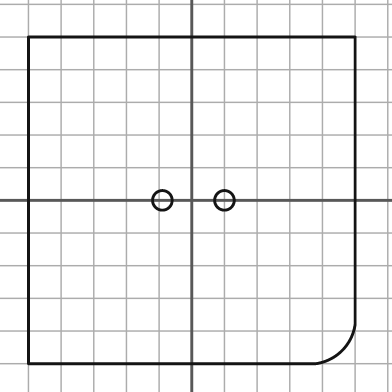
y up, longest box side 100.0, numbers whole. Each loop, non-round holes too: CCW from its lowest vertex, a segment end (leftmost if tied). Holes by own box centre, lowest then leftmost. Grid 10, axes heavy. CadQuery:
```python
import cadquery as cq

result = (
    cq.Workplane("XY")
    .moveTo(-50.0, -50.0)
    .lineTo(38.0, -50.0)
    .threePointArc((46.0, -46.0), (50.0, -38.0))
    .lineTo(50.0, 50.0)
    .lineTo(-50.0, 50.0)
    .close()
    .moveTo(-9.0, 0.0)
    .circle(3.0)
    .moveTo(10.0, 0.0)
    .circle(3.0)
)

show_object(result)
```